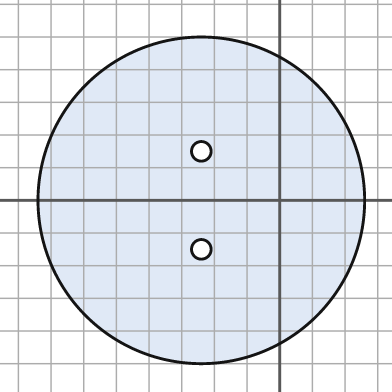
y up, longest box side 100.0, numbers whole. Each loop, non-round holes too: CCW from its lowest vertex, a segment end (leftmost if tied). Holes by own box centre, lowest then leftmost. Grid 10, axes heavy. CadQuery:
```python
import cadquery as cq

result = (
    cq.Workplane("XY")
    .moveTo(-24.0, 0.0)
    .circle(50.0)
    .moveTo(-24.0, -15.0)
    .circle(3.0)
    .moveTo(-24.0, 15.0)
    .circle(3.0)
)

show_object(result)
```